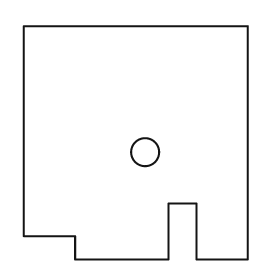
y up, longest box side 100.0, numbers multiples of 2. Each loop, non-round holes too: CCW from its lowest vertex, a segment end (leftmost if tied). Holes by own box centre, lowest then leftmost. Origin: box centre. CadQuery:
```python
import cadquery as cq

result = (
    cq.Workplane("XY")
    .moveTo(-26.0, -50.0)
    .lineTo(14.0, -50.0)
    .lineTo(14.0, -26.0)
    .lineTo(26.0, -26.0)
    .lineTo(26.0, -50.0)
    .lineTo(48.0, -50.0)
    .lineTo(48.0, 50.0)
    .lineTo(-48.0, 50.0)
    .lineTo(-48.0, -40.0)
    .lineTo(-26.0, -40.0)
    .close()
    .moveTo(4.0, -4.0)
    .circle(6.0)
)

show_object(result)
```